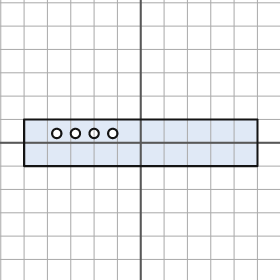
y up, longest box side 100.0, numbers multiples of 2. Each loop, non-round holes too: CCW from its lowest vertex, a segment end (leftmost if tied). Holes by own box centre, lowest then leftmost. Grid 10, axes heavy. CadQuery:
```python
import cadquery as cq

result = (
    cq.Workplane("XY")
    .moveTo(-50.0, -10.0)
    .lineTo(50.0, -10.0)
    .lineTo(50.0, 10.0)
    .lineTo(-50.0, 10.0)
    .close()
    .moveTo(-36.0, 4.0)
    .circle(2.0)
    .moveTo(-28.0, 4.0)
    .circle(2.0)
    .moveTo(-20.0, 4.0)
    .circle(2.0)
    .moveTo(-12.0, 4.0)
    .circle(2.0)
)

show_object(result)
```